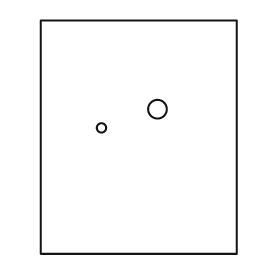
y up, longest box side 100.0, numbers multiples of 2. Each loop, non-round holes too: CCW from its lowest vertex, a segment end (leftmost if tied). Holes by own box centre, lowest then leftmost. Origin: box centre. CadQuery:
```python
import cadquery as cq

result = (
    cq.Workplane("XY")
    .moveTo(-42.0, -50.0)
    .lineTo(42.0, -50.0)
    .lineTo(42.0, 50.0)
    .lineTo(-42.0, 50.0)
    .close()
    .moveTo(-16.0, 4.0)
    .circle(2.0)
    .moveTo(8.0, 12.0)
    .circle(4.0)
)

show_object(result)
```